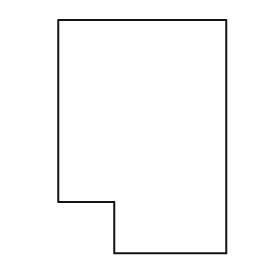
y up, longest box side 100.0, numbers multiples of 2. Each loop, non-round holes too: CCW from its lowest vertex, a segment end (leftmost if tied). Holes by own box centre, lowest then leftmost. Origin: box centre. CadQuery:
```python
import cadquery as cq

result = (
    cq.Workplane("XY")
    .moveTo(-12.0, -50.0)
    .lineTo(36.0, -50.0)
    .lineTo(36.0, 50.0)
    .lineTo(-36.0, 50.0)
    .lineTo(-36.0, -28.0)
    .lineTo(-12.0, -28.0)
    .close()
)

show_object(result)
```